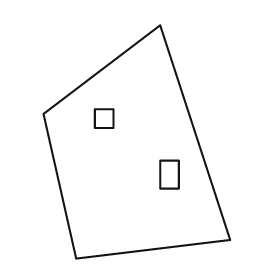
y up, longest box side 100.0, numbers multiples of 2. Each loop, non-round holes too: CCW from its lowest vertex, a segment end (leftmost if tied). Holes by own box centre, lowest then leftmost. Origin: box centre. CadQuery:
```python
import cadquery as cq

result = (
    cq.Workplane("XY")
    .moveTo(-26.0, -50.0)
    .lineTo(40.0, -42.0)
    .lineTo(10.0, 50.0)
    .lineTo(-40.0, 12.0)
    .close()
    .moveTo(10.0, -20.0)
    .lineTo(18.0, -20.0)
    .lineTo(18.0, -8.0)
    .lineTo(10.0, -8.0)
    .close()
    .moveTo(-18.0, 6.0)
    .lineTo(-10.0, 6.0)
    .lineTo(-10.0, 14.0)
    .lineTo(-18.0, 14.0)
    .close()
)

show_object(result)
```